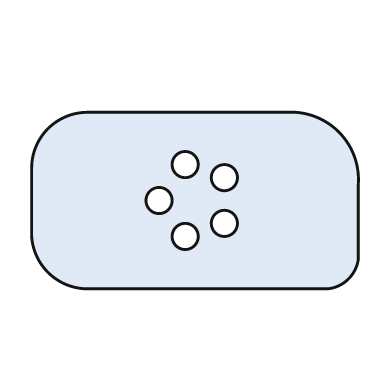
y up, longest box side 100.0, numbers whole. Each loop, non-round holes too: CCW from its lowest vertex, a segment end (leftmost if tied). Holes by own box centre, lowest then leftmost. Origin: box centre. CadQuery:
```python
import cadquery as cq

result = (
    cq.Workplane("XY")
    .moveTo(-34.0, -27.0)
    .lineTo(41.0, -27.0)
    .threePointArc((47.0, -24.0), (50.0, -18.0))
    .lineTo(50.0, 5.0)
    .threePointArc((44.0, 21.0), (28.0, 27.0))
    .lineTo(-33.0, 27.0)
    .threePointArc((-45.0, 22.0), (-50.0, 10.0))
    .lineTo(-50.0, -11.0)
    .threePointArc((-45.0, -22.0), (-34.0, -27.0))
    .close()
    .moveTo(-3.0, -11.0)
    .circle(4.0)
    .moveTo(9.0, -7.0)
    .circle(4.0)
    .moveTo(-11.0, 0.0)
    .circle(4.0)
    .moveTo(9.0, 7.0)
    .circle(4.0)
    .moveTo(-3.0, 11.0)
    .circle(4.0)
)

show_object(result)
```